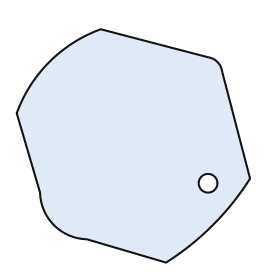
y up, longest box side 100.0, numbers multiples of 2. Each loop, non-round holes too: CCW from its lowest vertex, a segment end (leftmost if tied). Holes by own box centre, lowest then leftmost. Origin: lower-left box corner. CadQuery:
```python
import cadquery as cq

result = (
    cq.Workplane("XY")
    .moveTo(64.0, 0.0)
    .threePointArc((84.0, 16.0), (100.0, 36.0))
    .lineTo(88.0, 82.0)
    .threePointArc((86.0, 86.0), (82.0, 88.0))
    .lineTo(36.0, 100.0)
    .threePointArc((14.0, 86.0), (0.0, 64.0))
    .lineTo(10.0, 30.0)
    .threePointArc((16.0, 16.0), (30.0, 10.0))
    .close()
    .moveTo(82.0, 34.0)
    .circle(4.0)
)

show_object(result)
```